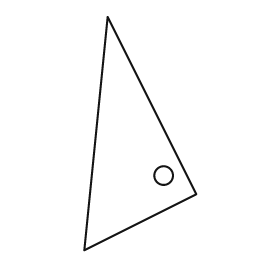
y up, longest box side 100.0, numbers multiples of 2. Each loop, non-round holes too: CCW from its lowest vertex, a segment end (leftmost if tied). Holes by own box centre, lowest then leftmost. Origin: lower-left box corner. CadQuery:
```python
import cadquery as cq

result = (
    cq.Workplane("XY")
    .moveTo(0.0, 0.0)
    .lineTo(48.0, 24.0)
    .lineTo(10.0, 100.0)
    .close()
    .moveTo(34.0, 32.0)
    .circle(4.0)
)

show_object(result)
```